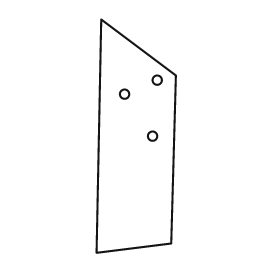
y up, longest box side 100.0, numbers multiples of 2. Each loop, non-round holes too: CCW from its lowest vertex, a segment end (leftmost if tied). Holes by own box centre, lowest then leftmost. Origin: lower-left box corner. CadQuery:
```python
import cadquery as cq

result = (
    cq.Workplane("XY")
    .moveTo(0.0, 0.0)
    .lineTo(32.0, 4.0)
    .lineTo(34.0, 76.0)
    .lineTo(2.0, 100.0)
    .close()
    .moveTo(24.0, 50.0)
    .circle(2.0)
    .moveTo(12.0, 68.0)
    .circle(2.0)
    .moveTo(26.0, 74.0)
    .circle(2.0)
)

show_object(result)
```